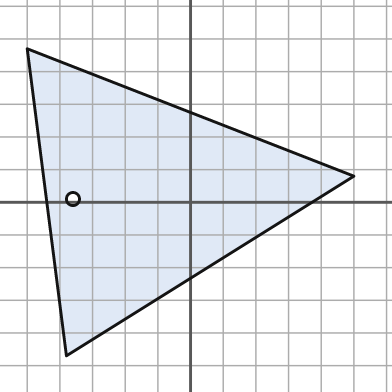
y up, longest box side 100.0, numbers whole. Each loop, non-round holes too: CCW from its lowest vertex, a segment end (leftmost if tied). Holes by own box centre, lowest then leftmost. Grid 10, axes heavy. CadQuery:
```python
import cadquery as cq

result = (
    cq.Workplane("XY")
    .moveTo(-38.0, -47.0)
    .lineTo(50.0, 8.0)
    .lineTo(-50.0, 47.0)
    .close()
    .moveTo(-36.0, 1.0)
    .circle(2.0)
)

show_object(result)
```